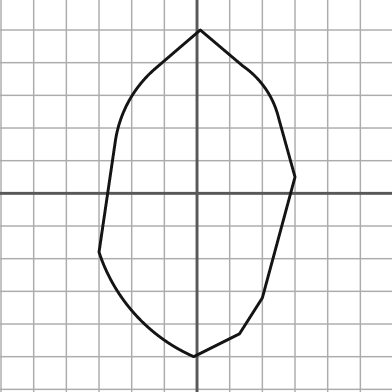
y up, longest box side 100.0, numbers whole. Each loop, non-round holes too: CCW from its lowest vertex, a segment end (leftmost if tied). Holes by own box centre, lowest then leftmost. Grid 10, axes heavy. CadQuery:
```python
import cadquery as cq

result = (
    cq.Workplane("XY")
    .moveTo(-1.0, -50.0)
    .lineTo(13.0, -43.0)
    .lineTo(20.0, -32.0)
    .lineTo(30.0, 5.0)
    .lineTo(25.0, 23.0)
    .threePointArc((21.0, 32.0), (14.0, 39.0))
    .lineTo(1.0, 50.0)
    .lineTo(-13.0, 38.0)
    .threePointArc((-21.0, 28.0), (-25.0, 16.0))
    .lineTo(-30.0, -18.0)
    .threePointArc((-19.0, -37.0), (-1.0, -50.0))
    .close()
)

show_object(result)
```